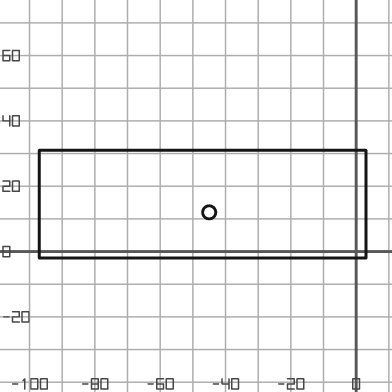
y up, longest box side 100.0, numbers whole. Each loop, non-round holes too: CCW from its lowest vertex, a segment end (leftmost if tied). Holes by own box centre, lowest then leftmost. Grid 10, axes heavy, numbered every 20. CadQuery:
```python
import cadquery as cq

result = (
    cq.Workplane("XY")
    .moveTo(-97.0, -2.0)
    .lineTo(3.0, -2.0)
    .lineTo(3.0, 31.0)
    .lineTo(-97.0, 31.0)
    .close()
    .moveTo(-45.0, 12.0)
    .circle(2.0)
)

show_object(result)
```